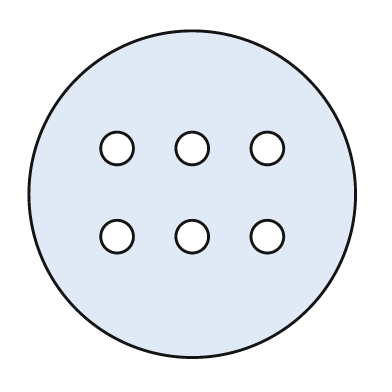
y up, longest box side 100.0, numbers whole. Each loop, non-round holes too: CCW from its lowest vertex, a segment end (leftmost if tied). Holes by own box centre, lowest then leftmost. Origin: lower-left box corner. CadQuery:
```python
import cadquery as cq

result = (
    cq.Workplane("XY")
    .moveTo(50.0, 50.0)
    .circle(50.0)
    .moveTo(27.0, 37.0)
    .circle(5.0)
    .moveTo(50.0, 37.0)
    .circle(5.0)
    .moveTo(73.0, 37.0)
    .circle(5.0)
    .moveTo(27.0, 64.0)
    .circle(5.0)
    .moveTo(50.0, 64.0)
    .circle(5.0)
    .moveTo(73.0, 64.0)
    .circle(5.0)
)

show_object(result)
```